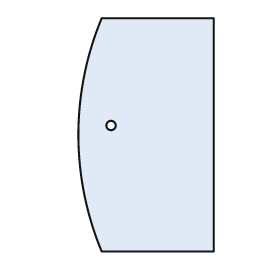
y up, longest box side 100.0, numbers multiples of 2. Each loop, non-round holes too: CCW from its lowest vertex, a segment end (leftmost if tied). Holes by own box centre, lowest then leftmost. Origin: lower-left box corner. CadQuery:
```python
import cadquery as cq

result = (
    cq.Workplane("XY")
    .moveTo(10.0, 0.0)
    .lineTo(58.0, 0.0)
    .lineTo(58.0, 100.0)
    .lineTo(10.0, 100.0)
    .threePointArc((0.0, 50.0), (10.0, 0.0))
    .close()
    .moveTo(14.0, 54.0)
    .circle(2.0)
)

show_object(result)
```